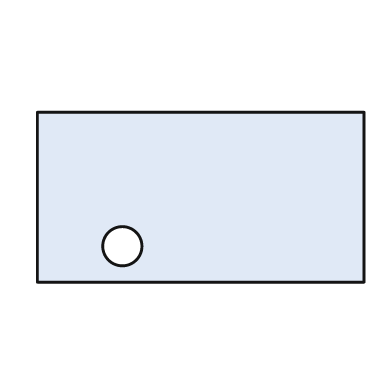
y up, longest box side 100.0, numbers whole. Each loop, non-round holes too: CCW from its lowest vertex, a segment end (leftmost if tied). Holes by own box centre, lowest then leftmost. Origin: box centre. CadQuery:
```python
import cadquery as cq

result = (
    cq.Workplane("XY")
    .moveTo(-50.0, -26.0)
    .lineTo(50.0, -26.0)
    .lineTo(50.0, 26.0)
    .lineTo(-50.0, 26.0)
    .close()
    .moveTo(-24.0, -15.0)
    .circle(6.0)
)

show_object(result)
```